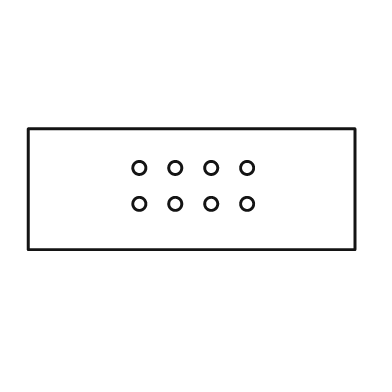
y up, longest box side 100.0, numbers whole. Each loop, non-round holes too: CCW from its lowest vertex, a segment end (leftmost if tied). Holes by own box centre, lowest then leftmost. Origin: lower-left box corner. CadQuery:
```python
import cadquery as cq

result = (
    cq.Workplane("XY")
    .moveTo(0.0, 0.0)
    .lineTo(100.0, 0.0)
    .lineTo(100.0, 37.0)
    .lineTo(0.0, 37.0)
    .close()
    .moveTo(34.0, 14.0)
    .circle(2.0)
    .moveTo(45.0, 14.0)
    .circle(2.0)
    .moveTo(56.0, 14.0)
    .circle(2.0)
    .moveTo(67.0, 14.0)
    .circle(2.0)
    .moveTo(34.0, 25.0)
    .circle(2.0)
    .moveTo(45.0, 25.0)
    .circle(2.0)
    .moveTo(56.0, 25.0)
    .circle(2.0)
    .moveTo(67.0, 25.0)
    .circle(2.0)
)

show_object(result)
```